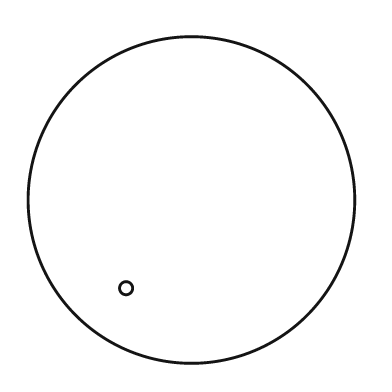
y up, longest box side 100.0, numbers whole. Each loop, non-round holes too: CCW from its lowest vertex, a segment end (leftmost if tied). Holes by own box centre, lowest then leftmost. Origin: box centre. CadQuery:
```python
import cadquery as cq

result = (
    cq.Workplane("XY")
    .moveTo(0.0, 0.0)
    .circle(50.0)
    .moveTo(-20.0, -27.0)
    .circle(2.0)
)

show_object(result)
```